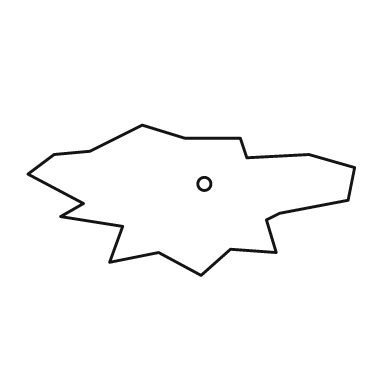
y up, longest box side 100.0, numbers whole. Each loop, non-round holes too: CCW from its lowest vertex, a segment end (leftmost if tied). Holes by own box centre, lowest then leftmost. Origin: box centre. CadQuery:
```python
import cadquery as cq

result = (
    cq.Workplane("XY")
    .moveTo(3.0, -23.0)
    .lineTo(12.0, -15.0)
    .lineTo(26.0, -16.0)
    .lineTo(23.0, -6.0)
    .lineTo(27.0, -4.0)
    .lineTo(48.0, 0.0)
    .lineTo(50.0, 10.0)
    .lineTo(36.0, 14.0)
    .lineTo(17.0, 13.0)
    .lineTo(15.0, 19.0)
    .lineTo(-2.0, 19.0)
    .lineTo(-15.0, 23.0)
    .lineTo(-31.0, 15.0)
    .lineTo(-42.0, 14.0)
    .lineTo(-50.0, 8.0)
    .lineTo(-33.0, -1.0)
    .lineTo(-40.0, -5.0)
    .lineTo(-21.0, -8.0)
    .lineTo(-25.0, -19.0)
    .lineTo(-10.0, -16.0)
    .close()
    .moveTo(4.0, 5.0)
    .circle(2.0)
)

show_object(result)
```